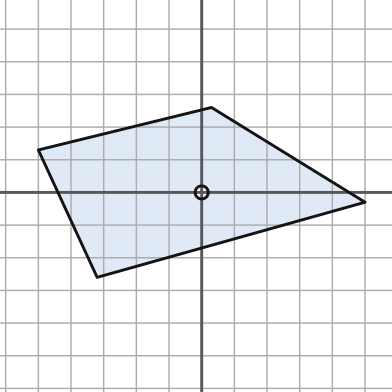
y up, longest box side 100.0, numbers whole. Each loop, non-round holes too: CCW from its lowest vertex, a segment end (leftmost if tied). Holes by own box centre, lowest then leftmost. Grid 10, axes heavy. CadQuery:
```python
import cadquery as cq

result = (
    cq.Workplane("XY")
    .moveTo(-32.0, -26.0)
    .lineTo(50.0, -3.0)
    .lineTo(3.0, 26.0)
    .lineTo(-50.0, 13.0)
    .close()
    .moveTo(0.0, 0.0)
    .circle(2.0)
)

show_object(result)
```